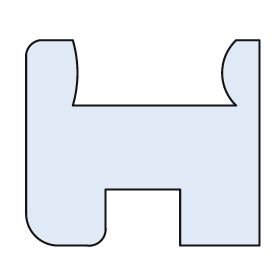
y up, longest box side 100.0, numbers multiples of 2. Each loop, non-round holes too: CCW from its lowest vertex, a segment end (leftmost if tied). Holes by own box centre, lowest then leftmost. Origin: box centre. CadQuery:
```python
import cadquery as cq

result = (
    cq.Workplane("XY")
    .moveTo(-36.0, -44.0)
    .lineTo(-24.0, -44.0)
    .threePointArc((-18.0, -42.0), (-16.0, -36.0))
    .lineTo(-16.0, -20.0)
    .lineTo(16.0, -20.0)
    .lineTo(16.0, -44.0)
    .lineTo(50.0, -44.0)
    .lineTo(50.0, 44.0)
    .lineTo(40.0, 44.0)
    .threePointArc((34.0, 30.0), (40.0, 16.0))
    .lineTo(-30.0, 16.0)
    .threePointArc((-28.0, 30.0), (-30.0, 44.0))
    .lineTo(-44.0, 44.0)
    .threePointArc((-48.0, 42.0), (-50.0, 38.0))
    .lineTo(-50.0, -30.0)
    .threePointArc((-46.0, -40.0), (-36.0, -44.0))
    .close()
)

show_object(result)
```